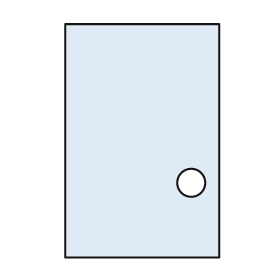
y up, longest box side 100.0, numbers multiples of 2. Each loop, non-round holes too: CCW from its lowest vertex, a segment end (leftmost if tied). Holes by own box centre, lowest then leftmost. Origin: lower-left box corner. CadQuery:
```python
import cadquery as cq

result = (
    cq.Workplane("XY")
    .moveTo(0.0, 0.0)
    .lineTo(66.0, 0.0)
    .lineTo(66.0, 100.0)
    .lineTo(0.0, 100.0)
    .close()
    .moveTo(54.0, 32.0)
    .circle(6.0)
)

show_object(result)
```